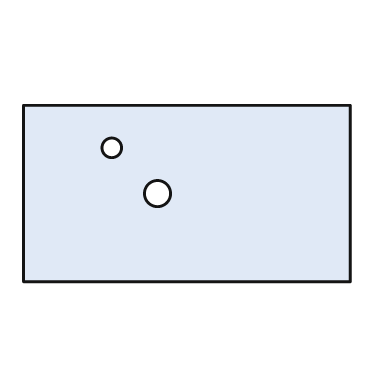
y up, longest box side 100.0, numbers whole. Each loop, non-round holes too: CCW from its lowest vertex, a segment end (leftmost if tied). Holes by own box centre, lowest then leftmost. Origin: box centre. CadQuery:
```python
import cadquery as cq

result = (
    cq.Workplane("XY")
    .moveTo(-50.0, -27.0)
    .lineTo(50.0, -27.0)
    .lineTo(50.0, 27.0)
    .lineTo(-50.0, 27.0)
    .close()
    .moveTo(-9.0, 0.0)
    .circle(4.0)
    .moveTo(-23.0, 14.0)
    .circle(3.0)
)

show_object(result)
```